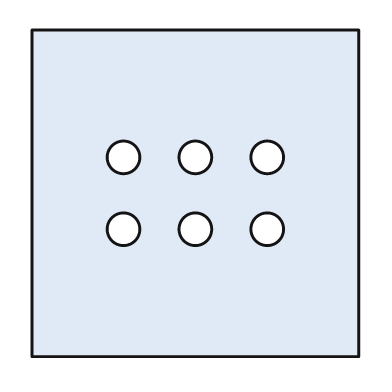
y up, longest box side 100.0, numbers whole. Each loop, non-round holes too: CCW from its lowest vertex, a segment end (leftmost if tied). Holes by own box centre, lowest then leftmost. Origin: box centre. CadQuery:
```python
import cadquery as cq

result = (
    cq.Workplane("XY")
    .moveTo(-50.0, -50.0)
    .lineTo(50.0, -50.0)
    .lineTo(50.0, 50.0)
    .lineTo(-50.0, 50.0)
    .close()
    .moveTo(-22.0, -11.0)
    .circle(5.0)
    .moveTo(0.0, -11.0)
    .circle(5.0)
    .moveTo(22.0, -11.0)
    .circle(5.0)
    .moveTo(-22.0, 11.0)
    .circle(5.0)
    .moveTo(0.0, 11.0)
    .circle(5.0)
    .moveTo(22.0, 11.0)
    .circle(5.0)
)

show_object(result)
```